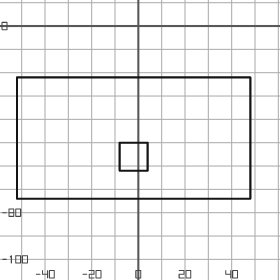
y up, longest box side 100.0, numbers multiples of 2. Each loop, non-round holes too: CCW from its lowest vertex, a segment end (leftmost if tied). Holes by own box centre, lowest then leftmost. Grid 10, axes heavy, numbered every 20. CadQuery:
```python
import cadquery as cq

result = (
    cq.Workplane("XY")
    .moveTo(-52.0, -74.0)
    .lineTo(48.0, -74.0)
    .lineTo(48.0, -22.0)
    .lineTo(-52.0, -22.0)
    .close()
    .moveTo(-8.0, -62.0)
    .lineTo(4.0, -62.0)
    .lineTo(4.0, -50.0)
    .lineTo(-8.0, -50.0)
    .close()
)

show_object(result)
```